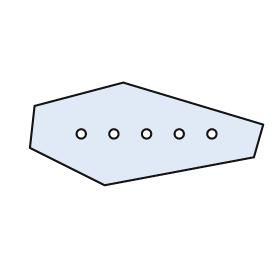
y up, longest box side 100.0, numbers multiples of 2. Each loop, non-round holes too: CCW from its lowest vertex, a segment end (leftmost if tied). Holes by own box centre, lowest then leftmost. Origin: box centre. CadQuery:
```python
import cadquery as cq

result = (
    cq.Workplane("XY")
    .moveTo(-18.0, -22.0)
    .lineTo(46.0, -10.0)
    .lineTo(50.0, 4.0)
    .lineTo(-10.0, 22.0)
    .lineTo(-48.0, 12.0)
    .lineTo(-50.0, -6.0)
    .close()
    .moveTo(-28.0, 0.0)
    .circle(2.0)
    .moveTo(-14.0, 0.0)
    .circle(2.0)
    .moveTo(0.0, 0.0)
    .circle(2.0)
    .moveTo(14.0, 0.0)
    .circle(2.0)
    .moveTo(28.0, 0.0)
    .circle(2.0)
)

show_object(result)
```